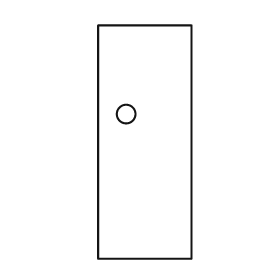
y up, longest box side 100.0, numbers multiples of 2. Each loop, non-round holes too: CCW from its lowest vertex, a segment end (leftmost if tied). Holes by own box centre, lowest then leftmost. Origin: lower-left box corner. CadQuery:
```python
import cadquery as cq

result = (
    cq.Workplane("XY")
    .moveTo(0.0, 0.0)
    .lineTo(40.0, 0.0)
    .lineTo(40.0, 100.0)
    .lineTo(0.0, 100.0)
    .close()
    .moveTo(12.0, 62.0)
    .circle(4.0)
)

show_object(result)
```